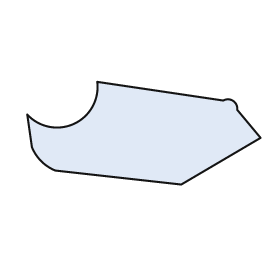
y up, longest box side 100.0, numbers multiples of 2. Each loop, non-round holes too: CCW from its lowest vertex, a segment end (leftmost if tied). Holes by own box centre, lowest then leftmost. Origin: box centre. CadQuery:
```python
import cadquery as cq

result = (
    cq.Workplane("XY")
    .moveTo(16.0, -22.0)
    .lineTo(50.0, -2.0)
    .lineTo(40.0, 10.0)
    .threePointArc((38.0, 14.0), (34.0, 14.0))
    .lineTo(-20.0, 22.0)
    .threePointArc((-30.0, 4.0), (-50.0, 8.0))
    .lineTo(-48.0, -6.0)
    .threePointArc((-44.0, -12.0), (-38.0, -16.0))
    .close()
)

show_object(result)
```